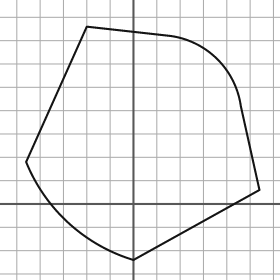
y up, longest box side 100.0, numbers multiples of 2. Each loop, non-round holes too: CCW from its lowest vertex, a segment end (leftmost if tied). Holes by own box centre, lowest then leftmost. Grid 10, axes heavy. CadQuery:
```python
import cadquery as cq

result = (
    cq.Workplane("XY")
    .moveTo(0.0, -24.0)
    .lineTo(54.0, 6.0)
    .lineTo(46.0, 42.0)
    .threePointArc((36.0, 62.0), (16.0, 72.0))
    .lineTo(-20.0, 76.0)
    .lineTo(-46.0, 18.0)
    .threePointArc((-28.0, -8.0), (0.0, -24.0))
    .close()
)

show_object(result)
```